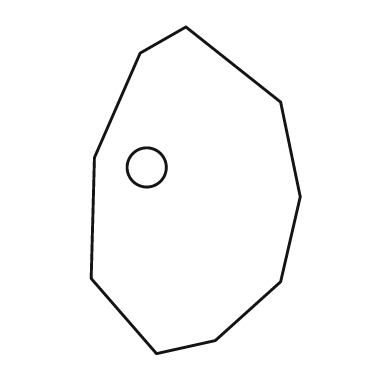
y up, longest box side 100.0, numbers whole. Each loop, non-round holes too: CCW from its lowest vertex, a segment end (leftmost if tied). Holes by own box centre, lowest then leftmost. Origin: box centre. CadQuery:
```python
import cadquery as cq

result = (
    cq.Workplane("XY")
    .moveTo(-12.0, -50.0)
    .lineTo(6.0, -46.0)
    .lineTo(26.0, -28.0)
    .lineTo(32.0, -2.0)
    .lineTo(26.0, 27.0)
    .lineTo(-3.0, 50.0)
    .lineTo(-17.0, 42.0)
    .lineTo(-31.0, 10.0)
    .lineTo(-32.0, -27.0)
    .close()
    .moveTo(-15.0, 7.0)
    .circle(6.0)
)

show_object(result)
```